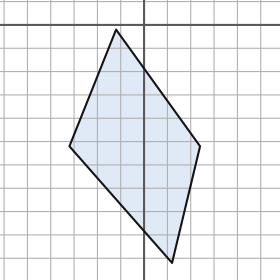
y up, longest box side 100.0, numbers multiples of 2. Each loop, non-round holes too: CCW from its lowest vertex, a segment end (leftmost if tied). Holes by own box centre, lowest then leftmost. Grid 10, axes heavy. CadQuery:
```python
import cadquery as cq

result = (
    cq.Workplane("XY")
    .moveTo(12.0, -102.0)
    .lineTo(24.0, -52.0)
    .lineTo(-12.0, -2.0)
    .lineTo(-32.0, -52.0)
    .close()
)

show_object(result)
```